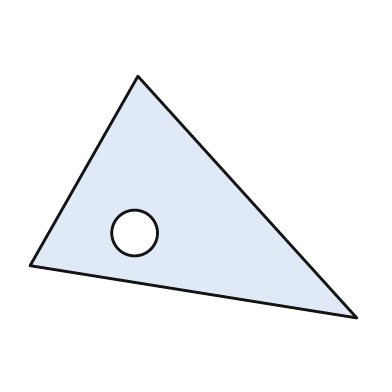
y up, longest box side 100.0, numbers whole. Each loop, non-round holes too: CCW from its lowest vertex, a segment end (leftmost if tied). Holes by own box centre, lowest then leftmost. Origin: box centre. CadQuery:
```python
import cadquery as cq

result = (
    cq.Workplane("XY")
    .moveTo(50.0, -37.0)
    .lineTo(-17.0, 37.0)
    .lineTo(-50.0, -21.0)
    .close()
    .moveTo(-18.0, -11.0)
    .circle(7.0)
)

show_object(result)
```